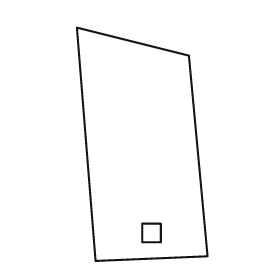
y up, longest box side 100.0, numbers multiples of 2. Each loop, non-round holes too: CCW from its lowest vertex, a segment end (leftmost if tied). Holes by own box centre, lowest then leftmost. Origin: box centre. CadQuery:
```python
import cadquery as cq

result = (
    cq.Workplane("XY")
    .moveTo(-20.0, -50.0)
    .lineTo(28.0, -48.0)
    .lineTo(20.0, 38.0)
    .lineTo(-28.0, 50.0)
    .close()
    .moveTo(0.0, -42.0)
    .lineTo(8.0, -42.0)
    .lineTo(8.0, -34.0)
    .lineTo(0.0, -34.0)
    .close()
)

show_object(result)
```